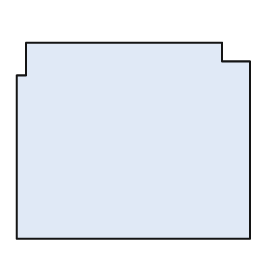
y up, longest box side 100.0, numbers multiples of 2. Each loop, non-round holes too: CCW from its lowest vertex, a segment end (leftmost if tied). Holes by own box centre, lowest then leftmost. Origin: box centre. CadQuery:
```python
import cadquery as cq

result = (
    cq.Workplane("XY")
    .moveTo(-50.0, -42.0)
    .lineTo(50.0, -42.0)
    .lineTo(50.0, 34.0)
    .lineTo(38.0, 34.0)
    .lineTo(38.0, 42.0)
    .lineTo(-46.0, 42.0)
    .lineTo(-46.0, 28.0)
    .lineTo(-50.0, 28.0)
    .close()
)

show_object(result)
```